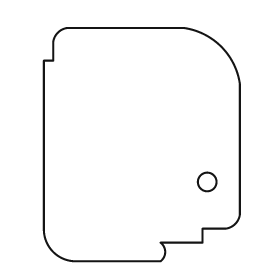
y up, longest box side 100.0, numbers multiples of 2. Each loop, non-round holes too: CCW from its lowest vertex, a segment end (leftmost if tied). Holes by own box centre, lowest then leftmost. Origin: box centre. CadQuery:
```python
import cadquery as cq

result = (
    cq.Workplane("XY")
    .moveTo(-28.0, -50.0)
    .lineTo(8.0, -50.0)
    .threePointArc((10.0, -46.0), (8.0, -42.0))
    .lineTo(26.0, -42.0)
    .lineTo(26.0, -36.0)
    .lineTo(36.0, -36.0)
    .threePointArc((40.0, -34.0), (42.0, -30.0))
    .lineTo(42.0, 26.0)
    .threePointArc((34.0, 42.0), (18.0, 50.0))
    .lineTo(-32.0, 50.0)
    .threePointArc((-36.0, 48.0), (-38.0, 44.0))
    .lineTo(-38.0, 36.0)
    .lineTo(-42.0, 36.0)
    .lineTo(-42.0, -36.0)
    .threePointArc((-38.0, -46.0), (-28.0, -50.0))
    .close()
    .moveTo(28.0, -16.0)
    .circle(4.0)
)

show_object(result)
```